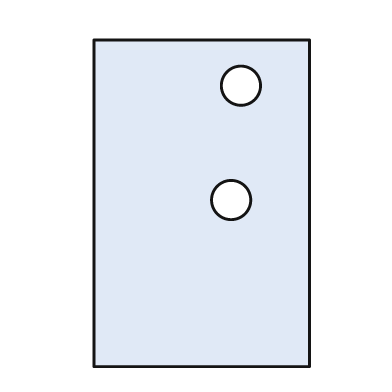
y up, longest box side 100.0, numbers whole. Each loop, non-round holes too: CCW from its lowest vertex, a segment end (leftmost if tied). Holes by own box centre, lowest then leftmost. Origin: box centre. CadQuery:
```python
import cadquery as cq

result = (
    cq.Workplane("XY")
    .moveTo(-33.0, -50.0)
    .lineTo(33.0, -50.0)
    .lineTo(33.0, 50.0)
    .lineTo(-33.0, 50.0)
    .close()
    .moveTo(9.0, 1.0)
    .circle(6.0)
    .moveTo(12.0, 36.0)
    .circle(6.0)
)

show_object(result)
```